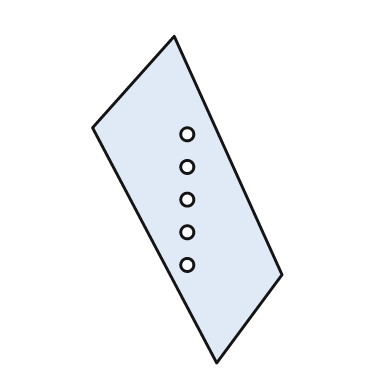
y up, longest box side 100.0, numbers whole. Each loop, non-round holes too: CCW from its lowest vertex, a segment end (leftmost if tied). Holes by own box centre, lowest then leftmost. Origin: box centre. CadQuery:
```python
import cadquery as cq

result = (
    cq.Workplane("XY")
    .moveTo(9.0, -50.0)
    .lineTo(29.0, -23.0)
    .lineTo(-4.0, 50.0)
    .lineTo(-29.0, 22.0)
    .close()
    .moveTo(0.0, -20.0)
    .circle(2.0)
    .moveTo(0.0, -10.0)
    .circle(2.0)
    .moveTo(0.0, 0.0)
    .circle(2.0)
    .moveTo(0.0, 10.0)
    .circle(2.0)
    .moveTo(0.0, 20.0)
    .circle(2.0)
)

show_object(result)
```